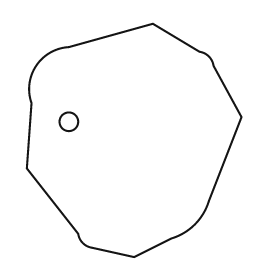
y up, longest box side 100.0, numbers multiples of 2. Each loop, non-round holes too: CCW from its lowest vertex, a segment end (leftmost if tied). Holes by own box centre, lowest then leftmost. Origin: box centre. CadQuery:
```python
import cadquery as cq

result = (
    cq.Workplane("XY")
    .moveTo(0.0, -50.0)
    .lineTo(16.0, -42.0)
    .threePointArc((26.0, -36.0), (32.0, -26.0))
    .lineTo(46.0, 10.0)
    .lineTo(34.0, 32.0)
    .threePointArc((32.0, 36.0), (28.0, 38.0))
    .lineTo(8.0, 50.0)
    .lineTo(-28.0, 40.0)
    .threePointArc((-42.0, 32.0), (-44.0, 16.0))
    .lineTo(-46.0, -12.0)
    .lineTo(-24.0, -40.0)
    .threePointArc((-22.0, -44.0), (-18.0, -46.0))
    .close()
    .moveTo(-28.0, 8.0)
    .circle(4.0)
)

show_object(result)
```